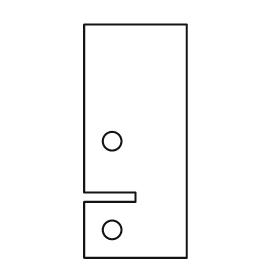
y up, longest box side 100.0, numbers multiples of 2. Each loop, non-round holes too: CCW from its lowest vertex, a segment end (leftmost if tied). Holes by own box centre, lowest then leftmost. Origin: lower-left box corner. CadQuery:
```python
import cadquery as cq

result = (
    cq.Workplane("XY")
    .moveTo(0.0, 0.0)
    .lineTo(44.0, 0.0)
    .lineTo(44.0, 100.0)
    .lineTo(0.0, 100.0)
    .lineTo(0.0, 28.0)
    .lineTo(22.0, 28.0)
    .lineTo(22.0, 24.0)
    .lineTo(0.0, 24.0)
    .close()
    .moveTo(12.0, 12.0)
    .circle(4.0)
    .moveTo(12.0, 50.0)
    .circle(4.0)
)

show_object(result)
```